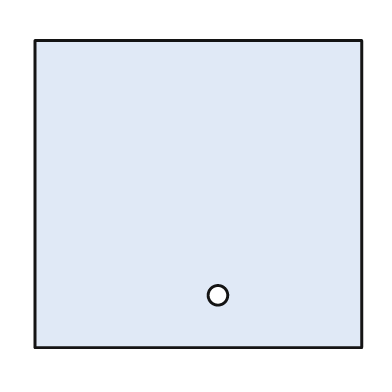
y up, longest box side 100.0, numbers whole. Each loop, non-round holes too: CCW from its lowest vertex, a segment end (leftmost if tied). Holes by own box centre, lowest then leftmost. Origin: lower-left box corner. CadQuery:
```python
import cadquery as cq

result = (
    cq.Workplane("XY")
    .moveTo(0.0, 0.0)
    .lineTo(100.0, 0.0)
    .lineTo(100.0, 94.0)
    .lineTo(0.0, 94.0)
    .close()
    .moveTo(56.0, 16.0)
    .circle(3.0)
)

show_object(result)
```